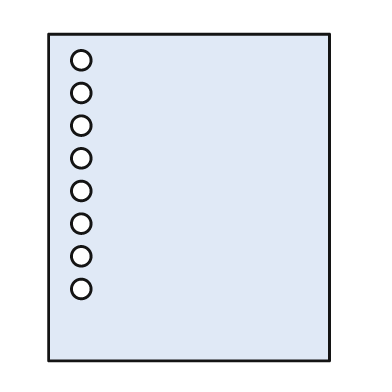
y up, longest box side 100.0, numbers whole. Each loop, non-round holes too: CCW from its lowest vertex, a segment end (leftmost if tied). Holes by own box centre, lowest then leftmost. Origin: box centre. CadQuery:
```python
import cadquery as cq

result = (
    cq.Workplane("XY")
    .moveTo(-43.0, -50.0)
    .lineTo(43.0, -50.0)
    .lineTo(43.0, 50.0)
    .lineTo(-43.0, 50.0)
    .close()
    .moveTo(-33.0, -28.0)
    .circle(3.0)
    .moveTo(-33.0, -18.0)
    .circle(3.0)
    .moveTo(-33.0, -8.0)
    .circle(3.0)
    .moveTo(-33.0, 2.0)
    .circle(3.0)
    .moveTo(-33.0, 12.0)
    .circle(3.0)
    .moveTo(-33.0, 22.0)
    .circle(3.0)
    .moveTo(-33.0, 32.0)
    .circle(3.0)
    .moveTo(-33.0, 42.0)
    .circle(3.0)
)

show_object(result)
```